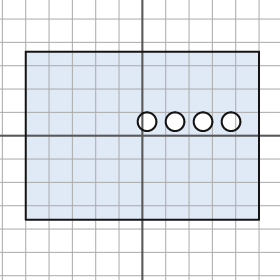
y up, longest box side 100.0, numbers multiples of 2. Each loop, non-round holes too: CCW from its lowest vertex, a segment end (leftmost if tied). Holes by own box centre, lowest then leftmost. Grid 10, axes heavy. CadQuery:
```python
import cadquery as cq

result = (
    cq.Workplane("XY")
    .moveTo(-50.0, -36.0)
    .lineTo(50.0, -36.0)
    .lineTo(50.0, 36.0)
    .lineTo(-50.0, 36.0)
    .close()
    .moveTo(2.0, 6.0)
    .circle(4.0)
    .moveTo(14.0, 6.0)
    .circle(4.0)
    .moveTo(26.0, 6.0)
    .circle(4.0)
    .moveTo(38.0, 6.0)
    .circle(4.0)
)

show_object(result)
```